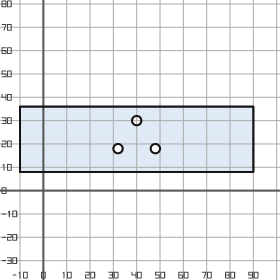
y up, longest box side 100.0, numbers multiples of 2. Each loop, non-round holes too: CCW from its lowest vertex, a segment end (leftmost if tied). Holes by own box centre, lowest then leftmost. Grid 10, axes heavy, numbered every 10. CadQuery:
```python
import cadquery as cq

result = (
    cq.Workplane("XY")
    .moveTo(-10.0, 8.0)
    .lineTo(90.0, 8.0)
    .lineTo(90.0, 36.0)
    .lineTo(-10.0, 36.0)
    .close()
    .moveTo(32.0, 18.0)
    .circle(2.0)
    .moveTo(48.0, 18.0)
    .circle(2.0)
    .moveTo(40.0, 30.0)
    .circle(2.0)
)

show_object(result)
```